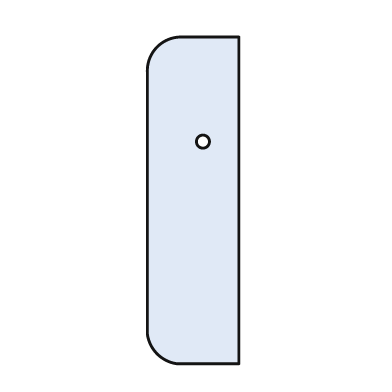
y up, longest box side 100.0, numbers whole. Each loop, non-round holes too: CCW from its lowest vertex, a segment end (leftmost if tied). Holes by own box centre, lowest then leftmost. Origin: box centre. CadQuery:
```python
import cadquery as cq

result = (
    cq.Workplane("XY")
    .moveTo(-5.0, -50.0)
    .lineTo(14.0, -50.0)
    .lineTo(14.0, 50.0)
    .lineTo(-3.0, 50.0)
    .threePointArc((-11.0, 47.0), (-14.0, 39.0))
    .lineTo(-14.0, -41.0)
    .threePointArc((-11.0, -47.0), (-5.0, -50.0))
    .close()
    .moveTo(3.0, 18.0)
    .circle(2.0)
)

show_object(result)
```